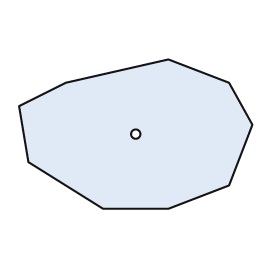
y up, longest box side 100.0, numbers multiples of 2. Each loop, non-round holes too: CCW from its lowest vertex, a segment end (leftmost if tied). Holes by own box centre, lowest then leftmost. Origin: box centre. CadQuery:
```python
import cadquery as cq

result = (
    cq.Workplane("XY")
    .moveTo(-14.0, -32.0)
    .lineTo(14.0, -32.0)
    .lineTo(40.0, -22.0)
    .lineTo(50.0, 4.0)
    .lineTo(40.0, 22.0)
    .lineTo(14.0, 32.0)
    .lineTo(-30.0, 22.0)
    .lineTo(-50.0, 12.0)
    .lineTo(-46.0, -12.0)
    .close()
    .moveTo(0.0, 0.0)
    .circle(2.0)
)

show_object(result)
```